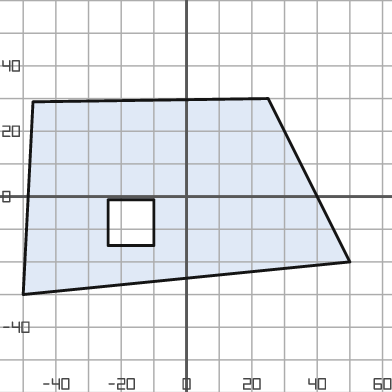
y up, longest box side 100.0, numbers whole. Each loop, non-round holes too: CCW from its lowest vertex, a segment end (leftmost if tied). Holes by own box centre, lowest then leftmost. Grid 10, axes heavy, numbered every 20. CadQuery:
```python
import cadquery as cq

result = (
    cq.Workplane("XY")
    .moveTo(-50.0, -30.0)
    .lineTo(50.0, -20.0)
    .lineTo(25.0, 30.0)
    .lineTo(-47.0, 29.0)
    .close()
    .moveTo(-24.0, -15.0)
    .lineTo(-10.0, -15.0)
    .lineTo(-10.0, -1.0)
    .lineTo(-24.0, -1.0)
    .close()
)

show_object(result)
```